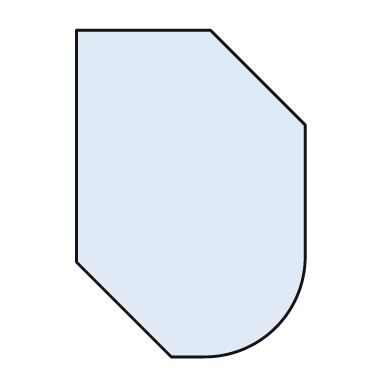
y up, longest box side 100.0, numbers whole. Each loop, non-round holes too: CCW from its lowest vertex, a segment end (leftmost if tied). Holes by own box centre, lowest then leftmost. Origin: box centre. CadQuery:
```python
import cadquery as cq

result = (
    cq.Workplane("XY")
    .moveTo(-6.0, -50.0)
    .lineTo(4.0, -50.0)
    .threePointArc((26.0, -41.0), (35.0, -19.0))
    .lineTo(35.0, 21.0)
    .lineTo(6.0, 50.0)
    .lineTo(-35.0, 50.0)
    .lineTo(-35.0, -21.0)
    .close()
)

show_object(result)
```